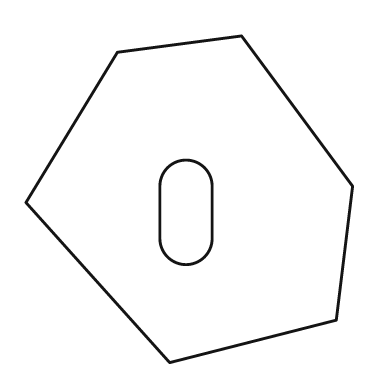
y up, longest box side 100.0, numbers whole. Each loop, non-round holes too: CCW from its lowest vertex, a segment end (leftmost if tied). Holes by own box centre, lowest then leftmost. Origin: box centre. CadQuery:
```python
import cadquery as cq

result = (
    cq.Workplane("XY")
    .moveTo(-6.0, -50.0)
    .lineTo(45.0, -37.0)
    .lineTo(50.0, 4.0)
    .lineTo(16.0, 50.0)
    .lineTo(-22.0, 45.0)
    .lineTo(-50.0, -1.0)
    .close()
    .moveTo(-9.0, -12.0)
    .threePointArc((-1.0, -20.0), (7.0, -12.0))
    .lineTo(7.0, 4.0)
    .threePointArc((-1.0, 12.0), (-9.0, 4.0))
    .close()
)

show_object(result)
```